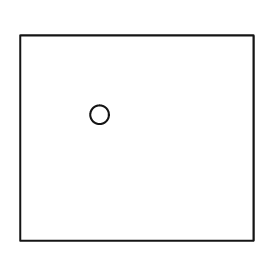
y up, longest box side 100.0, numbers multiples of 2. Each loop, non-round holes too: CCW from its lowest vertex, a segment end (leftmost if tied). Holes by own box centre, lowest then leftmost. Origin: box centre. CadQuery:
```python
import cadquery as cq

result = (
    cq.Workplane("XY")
    .moveTo(-50.0, -44.0)
    .lineTo(50.0, -44.0)
    .lineTo(50.0, 44.0)
    .lineTo(-50.0, 44.0)
    .close()
    .moveTo(-16.0, 10.0)
    .circle(4.0)
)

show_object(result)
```